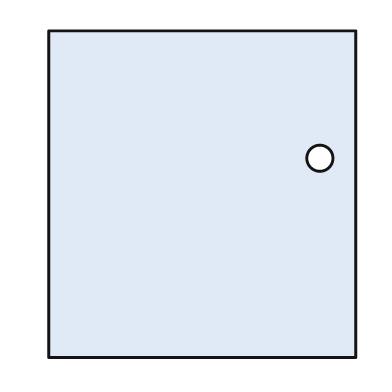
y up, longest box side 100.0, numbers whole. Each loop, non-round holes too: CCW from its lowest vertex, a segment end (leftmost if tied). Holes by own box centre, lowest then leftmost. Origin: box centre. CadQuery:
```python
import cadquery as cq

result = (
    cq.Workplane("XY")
    .moveTo(-47.0, -50.0)
    .lineTo(47.0, -50.0)
    .lineTo(47.0, 50.0)
    .lineTo(-47.0, 50.0)
    .close()
    .moveTo(36.0, 11.0)
    .circle(4.0)
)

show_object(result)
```